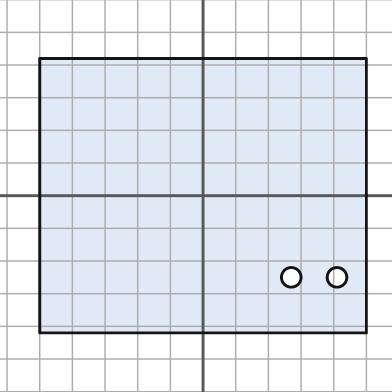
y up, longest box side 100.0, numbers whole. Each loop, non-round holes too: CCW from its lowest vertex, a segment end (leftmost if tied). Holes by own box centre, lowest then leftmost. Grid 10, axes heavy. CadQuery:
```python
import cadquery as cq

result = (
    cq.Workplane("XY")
    .moveTo(-50.0, -42.0)
    .lineTo(50.0, -42.0)
    .lineTo(50.0, 42.0)
    .lineTo(-50.0, 42.0)
    .close()
    .moveTo(27.0, -25.0)
    .circle(3.0)
    .moveTo(41.0, -25.0)
    .circle(3.0)
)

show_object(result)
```